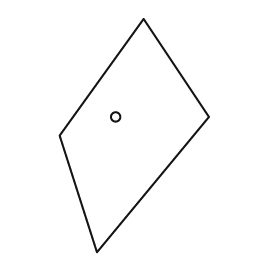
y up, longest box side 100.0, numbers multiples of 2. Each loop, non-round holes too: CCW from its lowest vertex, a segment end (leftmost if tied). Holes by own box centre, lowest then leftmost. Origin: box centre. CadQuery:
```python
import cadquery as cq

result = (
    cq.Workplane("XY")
    .moveTo(-16.0, -50.0)
    .lineTo(32.0, 8.0)
    .lineTo(4.0, 50.0)
    .lineTo(-32.0, 0.0)
    .close()
    .moveTo(-8.0, 8.0)
    .circle(2.0)
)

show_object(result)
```